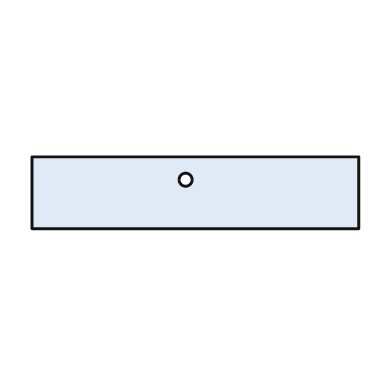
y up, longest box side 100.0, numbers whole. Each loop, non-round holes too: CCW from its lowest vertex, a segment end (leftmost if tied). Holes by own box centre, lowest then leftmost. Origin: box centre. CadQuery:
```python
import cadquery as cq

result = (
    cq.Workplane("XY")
    .moveTo(-50.0, -11.0)
    .lineTo(50.0, -11.0)
    .lineTo(50.0, 11.0)
    .lineTo(-50.0, 11.0)
    .close()
    .moveTo(-3.0, 4.0)
    .circle(2.0)
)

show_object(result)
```